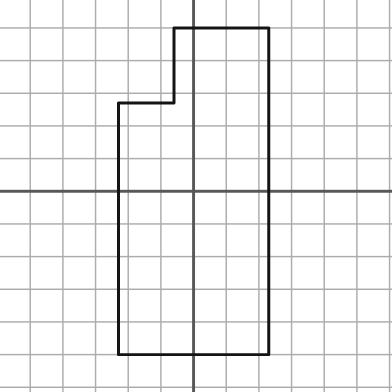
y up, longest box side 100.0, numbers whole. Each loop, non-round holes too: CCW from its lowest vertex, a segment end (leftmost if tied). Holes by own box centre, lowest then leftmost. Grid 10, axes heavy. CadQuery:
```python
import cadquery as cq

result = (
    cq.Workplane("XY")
    .moveTo(-23.0, -50.0)
    .lineTo(23.0, -50.0)
    .lineTo(23.0, 50.0)
    .lineTo(-6.0, 50.0)
    .lineTo(-6.0, 27.0)
    .lineTo(-23.0, 27.0)
    .close()
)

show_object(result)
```